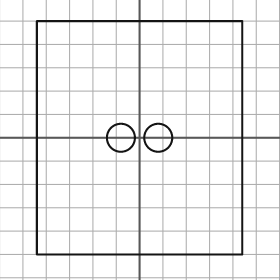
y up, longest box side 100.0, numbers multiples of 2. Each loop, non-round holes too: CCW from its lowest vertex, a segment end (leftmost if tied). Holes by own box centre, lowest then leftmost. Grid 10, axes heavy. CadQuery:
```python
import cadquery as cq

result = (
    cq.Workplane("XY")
    .moveTo(-44.0, -50.0)
    .lineTo(44.0, -50.0)
    .lineTo(44.0, 50.0)
    .lineTo(-44.0, 50.0)
    .close()
    .moveTo(-8.0, 0.0)
    .circle(6.0)
    .moveTo(8.0, 0.0)
    .circle(6.0)
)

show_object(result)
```